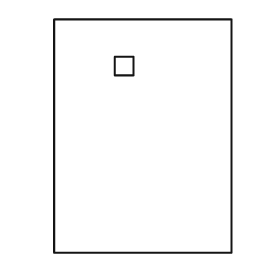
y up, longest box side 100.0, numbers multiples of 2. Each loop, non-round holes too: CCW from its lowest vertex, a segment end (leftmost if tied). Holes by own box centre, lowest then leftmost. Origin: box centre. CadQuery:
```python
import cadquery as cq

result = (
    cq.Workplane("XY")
    .moveTo(-38.0, -50.0)
    .lineTo(38.0, -50.0)
    .lineTo(38.0, 50.0)
    .lineTo(-38.0, 50.0)
    .close()
    .moveTo(-12.0, 26.0)
    .lineTo(-4.0, 26.0)
    .lineTo(-4.0, 34.0)
    .lineTo(-12.0, 34.0)
    .close()
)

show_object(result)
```